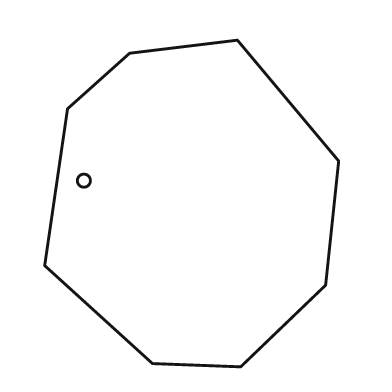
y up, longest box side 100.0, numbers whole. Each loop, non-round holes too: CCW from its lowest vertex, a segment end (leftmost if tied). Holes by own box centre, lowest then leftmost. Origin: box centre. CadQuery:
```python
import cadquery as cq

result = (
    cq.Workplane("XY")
    .moveTo(15.0, -50.0)
    .lineTo(41.0, -25.0)
    .lineTo(45.0, 13.0)
    .lineTo(14.0, 50.0)
    .lineTo(-19.0, 46.0)
    .lineTo(-38.0, 29.0)
    .lineTo(-45.0, -19.0)
    .lineTo(-12.0, -49.0)
    .close()
    .moveTo(-33.0, 7.0)
    .circle(2.0)
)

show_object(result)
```